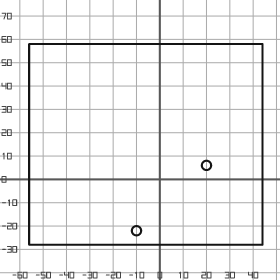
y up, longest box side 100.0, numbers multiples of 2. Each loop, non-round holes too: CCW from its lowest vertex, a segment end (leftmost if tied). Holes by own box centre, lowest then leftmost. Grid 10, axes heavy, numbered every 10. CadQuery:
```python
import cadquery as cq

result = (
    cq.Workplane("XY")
    .moveTo(-56.0, -28.0)
    .lineTo(44.0, -28.0)
    .lineTo(44.0, 58.0)
    .lineTo(-56.0, 58.0)
    .close()
    .moveTo(-10.0, -22.0)
    .circle(2.0)
    .moveTo(20.0, 6.0)
    .circle(2.0)
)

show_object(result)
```